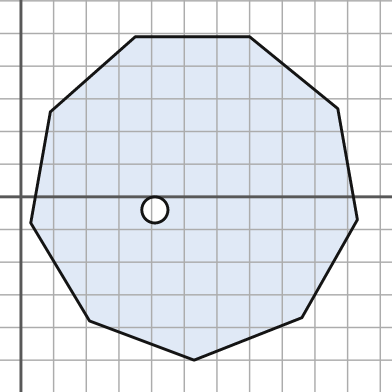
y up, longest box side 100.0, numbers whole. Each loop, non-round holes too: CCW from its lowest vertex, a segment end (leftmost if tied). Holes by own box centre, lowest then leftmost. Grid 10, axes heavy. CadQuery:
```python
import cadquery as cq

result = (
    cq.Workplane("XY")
    .moveTo(53.0, -50.0)
    .lineTo(86.0, -37.0)
    .lineTo(103.0, -7.0)
    .lineTo(97.0, 27.0)
    .lineTo(70.0, 49.0)
    .lineTo(35.0, 49.0)
    .lineTo(9.0, 26.0)
    .lineTo(3.0, -8.0)
    .lineTo(21.0, -38.0)
    .close()
    .moveTo(41.0, -4.0)
    .circle(4.0)
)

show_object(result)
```